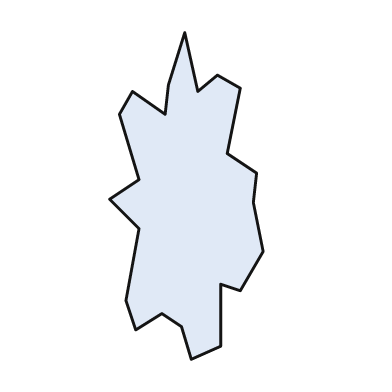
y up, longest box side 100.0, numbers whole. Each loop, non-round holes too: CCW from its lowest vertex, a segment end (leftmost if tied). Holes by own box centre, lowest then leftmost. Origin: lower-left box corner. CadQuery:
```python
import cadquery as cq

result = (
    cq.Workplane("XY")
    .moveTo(25.0, 0.0)
    .lineTo(34.0, 4.0)
    .lineTo(34.0, 23.0)
    .lineTo(40.0, 21.0)
    .lineTo(47.0, 33.0)
    .lineTo(44.0, 48.0)
    .lineTo(45.0, 57.0)
    .lineTo(36.0, 63.0)
    .lineTo(40.0, 83.0)
    .lineTo(33.0, 87.0)
    .lineTo(27.0, 82.0)
    .lineTo(23.0, 100.0)
    .lineTo(18.0, 84.0)
    .lineTo(17.0, 75.0)
    .lineTo(7.0, 82.0)
    .lineTo(3.0, 75.0)
    .lineTo(9.0, 55.0)
    .lineTo(0.0, 49.0)
    .lineTo(9.0, 40.0)
    .lineTo(5.0, 18.0)
    .lineTo(8.0, 9.0)
    .lineTo(16.0, 14.0)
    .lineTo(22.0, 10.0)
    .close()
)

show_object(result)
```